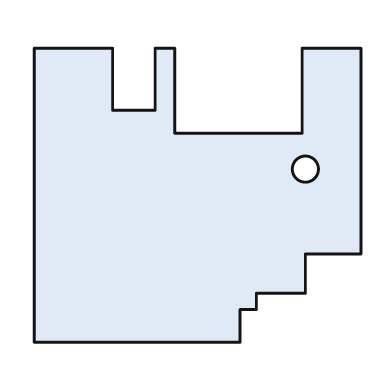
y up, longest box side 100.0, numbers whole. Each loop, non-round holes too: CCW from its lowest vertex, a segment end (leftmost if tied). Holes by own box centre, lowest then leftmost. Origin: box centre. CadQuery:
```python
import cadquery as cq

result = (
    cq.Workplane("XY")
    .moveTo(-50.0, -45.0)
    .lineTo(13.0, -45.0)
    .lineTo(13.0, -35.0)
    .lineTo(18.0, -35.0)
    .lineTo(18.0, -30.0)
    .lineTo(33.0, -30.0)
    .lineTo(33.0, -18.0)
    .lineTo(50.0, -18.0)
    .lineTo(50.0, 45.0)
    .lineTo(32.0, 45.0)
    .lineTo(32.0, 19.0)
    .lineTo(-7.0, 19.0)
    .lineTo(-7.0, 45.0)
    .lineTo(-13.0, 45.0)
    .lineTo(-13.0, 26.0)
    .lineTo(-26.0, 26.0)
    .lineTo(-26.0, 45.0)
    .lineTo(-50.0, 45.0)
    .close()
    .moveTo(33.0, 8.0)
    .circle(4.0)
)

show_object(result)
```